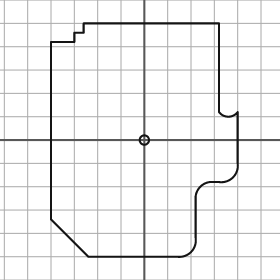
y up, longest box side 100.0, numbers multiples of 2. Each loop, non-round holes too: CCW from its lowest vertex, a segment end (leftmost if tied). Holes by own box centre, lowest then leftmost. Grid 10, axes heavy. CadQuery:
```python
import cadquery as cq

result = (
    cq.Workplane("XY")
    .moveTo(-24.0, -50.0)
    .lineTo(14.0, -50.0)
    .threePointArc((20.0, -48.0), (22.0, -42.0))
    .lineTo(22.0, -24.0)
    .threePointArc((24.0, -20.0), (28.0, -18.0))
    .lineTo(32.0, -18.0)
    .threePointArc((38.0, -16.0), (40.0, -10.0))
    .lineTo(40.0, 12.0)
    .threePointArc((36.0, 10.0), (32.0, 12.0))
    .lineTo(32.0, 50.0)
    .lineTo(-26.0, 50.0)
    .lineTo(-26.0, 46.0)
    .lineTo(-30.0, 46.0)
    .lineTo(-30.0, 42.0)
    .lineTo(-40.0, 42.0)
    .lineTo(-40.0, -34.0)
    .close()
    .moveTo(0.0, 0.0)
    .circle(2.0)
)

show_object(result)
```